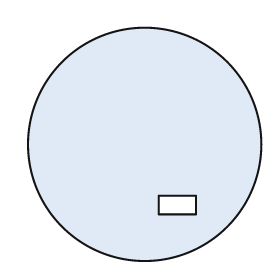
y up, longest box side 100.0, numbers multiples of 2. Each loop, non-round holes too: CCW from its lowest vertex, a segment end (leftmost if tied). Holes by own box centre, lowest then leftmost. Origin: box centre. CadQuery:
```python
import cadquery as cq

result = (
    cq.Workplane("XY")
    .moveTo(0.0, 0.0)
    .circle(50.0)
    .moveTo(6.0, -30.0)
    .lineTo(22.0, -30.0)
    .lineTo(22.0, -22.0)
    .lineTo(6.0, -22.0)
    .close()
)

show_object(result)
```